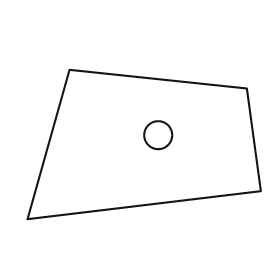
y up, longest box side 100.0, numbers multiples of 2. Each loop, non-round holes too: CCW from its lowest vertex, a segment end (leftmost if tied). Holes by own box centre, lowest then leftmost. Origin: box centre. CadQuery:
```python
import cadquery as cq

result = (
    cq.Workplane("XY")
    .moveTo(-50.0, -32.0)
    .lineTo(50.0, -20.0)
    .lineTo(44.0, 24.0)
    .lineTo(-32.0, 32.0)
    .close()
    .moveTo(6.0, 4.0)
    .circle(6.0)
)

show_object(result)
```